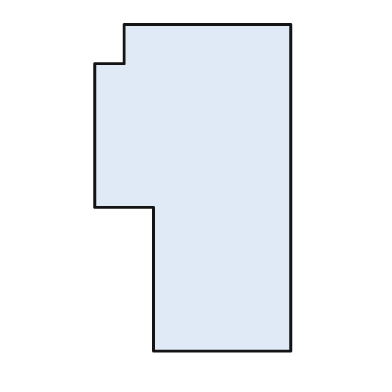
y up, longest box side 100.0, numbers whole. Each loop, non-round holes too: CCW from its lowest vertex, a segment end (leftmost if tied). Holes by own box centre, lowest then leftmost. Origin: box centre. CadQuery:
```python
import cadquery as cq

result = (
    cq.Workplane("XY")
    .moveTo(-12.0, -50.0)
    .lineTo(30.0, -50.0)
    .lineTo(30.0, 50.0)
    .lineTo(-21.0, 50.0)
    .lineTo(-21.0, 38.0)
    .lineTo(-30.0, 38.0)
    .lineTo(-30.0, -6.0)
    .lineTo(-12.0, -6.0)
    .close()
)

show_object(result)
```